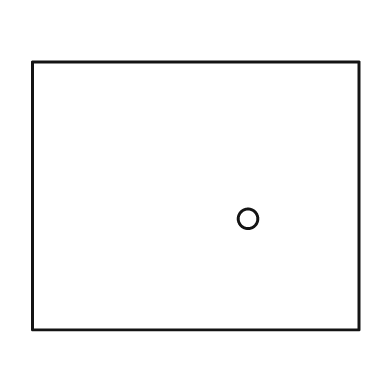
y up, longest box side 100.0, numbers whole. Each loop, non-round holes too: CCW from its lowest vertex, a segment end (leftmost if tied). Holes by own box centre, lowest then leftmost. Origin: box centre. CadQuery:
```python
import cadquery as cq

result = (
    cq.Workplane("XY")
    .moveTo(-50.0, -41.0)
    .lineTo(50.0, -41.0)
    .lineTo(50.0, 41.0)
    .lineTo(-50.0, 41.0)
    .close()
    .moveTo(16.0, -7.0)
    .circle(3.0)
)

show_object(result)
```